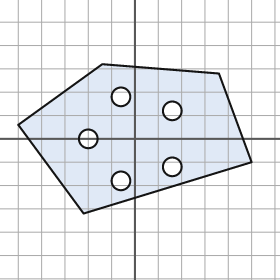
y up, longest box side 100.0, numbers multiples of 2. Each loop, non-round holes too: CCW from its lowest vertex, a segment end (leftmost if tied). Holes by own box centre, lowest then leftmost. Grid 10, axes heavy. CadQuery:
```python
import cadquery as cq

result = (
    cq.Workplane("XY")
    .moveTo(-22.0, -32.0)
    .lineTo(50.0, -10.0)
    .lineTo(36.0, 28.0)
    .lineTo(-14.0, 32.0)
    .lineTo(-50.0, 6.0)
    .close()
    .moveTo(-6.0, -18.0)
    .circle(4.0)
    .moveTo(16.0, -12.0)
    .circle(4.0)
    .moveTo(-20.0, 0.0)
    .circle(4.0)
    .moveTo(16.0, 12.0)
    .circle(4.0)
    .moveTo(-6.0, 18.0)
    .circle(4.0)
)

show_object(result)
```